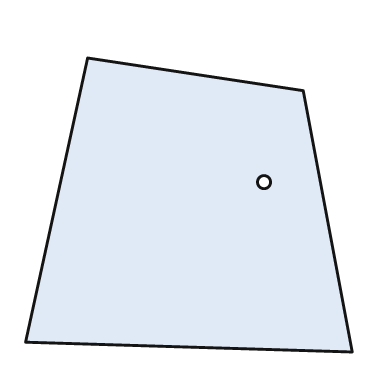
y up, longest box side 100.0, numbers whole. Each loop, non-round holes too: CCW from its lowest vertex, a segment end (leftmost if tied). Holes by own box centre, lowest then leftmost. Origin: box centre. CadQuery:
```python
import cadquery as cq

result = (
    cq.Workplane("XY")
    .moveTo(50.0, -45.0)
    .lineTo(35.0, 35.0)
    .lineTo(-31.0, 45.0)
    .lineTo(-50.0, -42.0)
    .close()
    .moveTo(23.0, 7.0)
    .circle(2.0)
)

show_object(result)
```